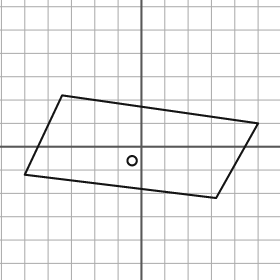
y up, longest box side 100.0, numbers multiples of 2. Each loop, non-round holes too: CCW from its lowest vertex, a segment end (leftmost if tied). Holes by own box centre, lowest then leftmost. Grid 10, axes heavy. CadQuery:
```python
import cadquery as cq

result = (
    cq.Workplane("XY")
    .moveTo(32.0, -22.0)
    .lineTo(50.0, 10.0)
    .lineTo(-34.0, 22.0)
    .lineTo(-50.0, -12.0)
    .close()
    .moveTo(-4.0, -6.0)
    .circle(2.0)
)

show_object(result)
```